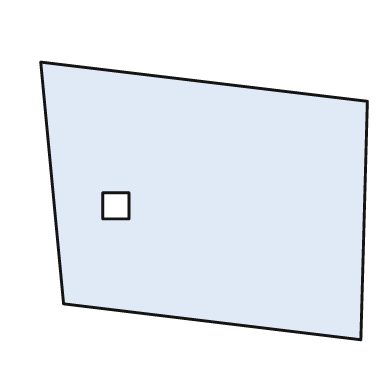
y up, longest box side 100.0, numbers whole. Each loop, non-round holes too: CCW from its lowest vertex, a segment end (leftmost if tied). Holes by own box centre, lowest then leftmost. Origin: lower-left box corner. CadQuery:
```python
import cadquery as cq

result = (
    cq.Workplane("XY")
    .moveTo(98.0, 0.0)
    .lineTo(100.0, 73.0)
    .lineTo(0.0, 85.0)
    .lineTo(7.0, 11.0)
    .close()
    .moveTo(19.0, 37.0)
    .lineTo(27.0, 37.0)
    .lineTo(27.0, 45.0)
    .lineTo(19.0, 45.0)
    .close()
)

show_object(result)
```